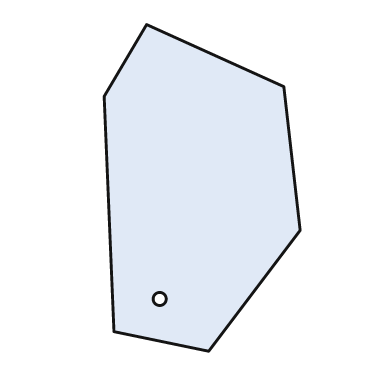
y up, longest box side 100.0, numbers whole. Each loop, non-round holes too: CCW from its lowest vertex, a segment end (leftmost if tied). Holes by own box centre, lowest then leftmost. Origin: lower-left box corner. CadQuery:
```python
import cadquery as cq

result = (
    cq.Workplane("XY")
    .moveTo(32.0, 0.0)
    .lineTo(60.0, 37.0)
    .lineTo(55.0, 81.0)
    .lineTo(13.0, 100.0)
    .lineTo(0.0, 78.0)
    .lineTo(3.0, 6.0)
    .close()
    .moveTo(17.0, 16.0)
    .circle(2.0)
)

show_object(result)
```